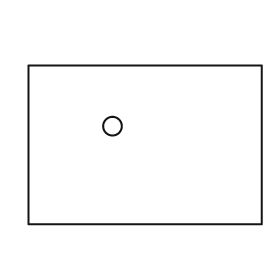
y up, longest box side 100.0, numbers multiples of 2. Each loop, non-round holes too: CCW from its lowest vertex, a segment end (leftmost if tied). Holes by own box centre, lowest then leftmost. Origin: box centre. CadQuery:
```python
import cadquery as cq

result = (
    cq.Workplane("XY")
    .moveTo(-50.0, -34.0)
    .lineTo(50.0, -34.0)
    .lineTo(50.0, 34.0)
    .lineTo(-50.0, 34.0)
    .close()
    .moveTo(-14.0, 8.0)
    .circle(4.0)
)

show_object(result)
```